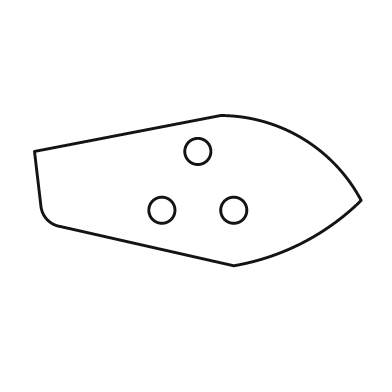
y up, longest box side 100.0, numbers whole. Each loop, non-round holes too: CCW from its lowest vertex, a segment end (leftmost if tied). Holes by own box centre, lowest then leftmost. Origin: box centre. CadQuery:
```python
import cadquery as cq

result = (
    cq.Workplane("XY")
    .moveTo(11.0, -23.0)
    .threePointArc((32.0, -16.0), (50.0, -3.0))
    .threePointArc((32.0, 16.0), (7.0, 23.0))
    .lineTo(-50.0, 12.0)
    .lineTo(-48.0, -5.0)
    .threePointArc((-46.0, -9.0), (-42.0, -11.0))
    .close()
    .moveTo(-11.0, -6.0)
    .circle(4.0)
    .moveTo(11.0, -6.0)
    .circle(4.0)
    .moveTo(0.0, 12.0)
    .circle(4.0)
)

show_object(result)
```